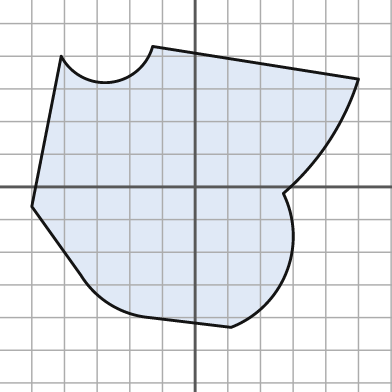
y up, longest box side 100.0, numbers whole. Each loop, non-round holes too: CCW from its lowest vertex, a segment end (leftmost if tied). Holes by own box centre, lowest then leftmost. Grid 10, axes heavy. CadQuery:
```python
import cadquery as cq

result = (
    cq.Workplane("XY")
    .moveTo(11.0, -43.0)
    .threePointArc((28.0, -26.0), (27.0, -2.0))
    .threePointArc((41.0, 14.0), (50.0, 33.0))
    .lineTo(-13.0, 43.0)
    .threePointArc((-26.0, 32.0), (-41.0, 40.0))
    .lineTo(-50.0, -6.0)
    .lineTo(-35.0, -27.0)
    .threePointArc((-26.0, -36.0), (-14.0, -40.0))
    .close()
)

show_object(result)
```